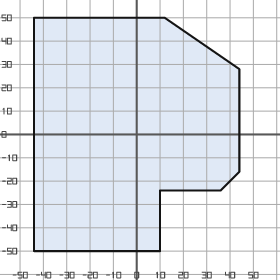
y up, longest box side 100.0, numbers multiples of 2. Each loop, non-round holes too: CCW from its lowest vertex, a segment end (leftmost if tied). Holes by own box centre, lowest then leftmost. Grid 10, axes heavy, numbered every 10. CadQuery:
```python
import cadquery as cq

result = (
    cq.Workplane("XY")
    .moveTo(-44.0, -50.0)
    .lineTo(10.0, -50.0)
    .lineTo(10.0, -24.0)
    .lineTo(36.0, -24.0)
    .lineTo(44.0, -16.0)
    .lineTo(44.0, 28.0)
    .lineTo(12.0, 50.0)
    .lineTo(-44.0, 50.0)
    .close()
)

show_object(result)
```